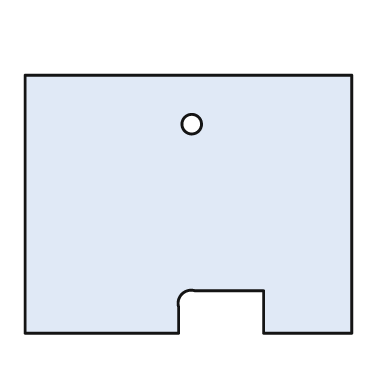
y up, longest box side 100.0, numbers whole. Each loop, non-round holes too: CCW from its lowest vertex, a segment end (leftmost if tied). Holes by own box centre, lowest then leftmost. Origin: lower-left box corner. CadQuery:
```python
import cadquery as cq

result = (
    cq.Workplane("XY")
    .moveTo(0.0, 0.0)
    .lineTo(47.0, 0.0)
    .lineTo(47.0, 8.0)
    .threePointArc((48.0, 12.0), (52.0, 13.0))
    .lineTo(73.0, 13.0)
    .lineTo(73.0, 0.0)
    .lineTo(100.0, 0.0)
    .lineTo(100.0, 79.0)
    .lineTo(0.0, 79.0)
    .close()
    .moveTo(51.0, 64.0)
    .circle(3.0)
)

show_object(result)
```